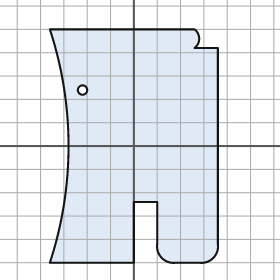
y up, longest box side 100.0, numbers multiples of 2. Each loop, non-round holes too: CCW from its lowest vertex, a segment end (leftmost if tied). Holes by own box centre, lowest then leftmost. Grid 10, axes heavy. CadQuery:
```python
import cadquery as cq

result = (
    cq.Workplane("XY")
    .moveTo(-36.0, -50.0)
    .lineTo(0.0, -50.0)
    .lineTo(0.0, -24.0)
    .lineTo(10.0, -24.0)
    .lineTo(10.0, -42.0)
    .threePointArc((12.0, -48.0), (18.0, -50.0))
    .lineTo(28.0, -50.0)
    .threePointArc((34.0, -48.0), (36.0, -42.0))
    .lineTo(36.0, 42.0)
    .lineTo(26.0, 42.0)
    .threePointArc((28.0, 46.0), (26.0, 50.0))
    .lineTo(-36.0, 50.0)
    .threePointArc((-28.0, 0.0), (-36.0, -50.0))
    .close()
    .moveTo(-22.0, 24.0)
    .circle(2.0)
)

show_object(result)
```